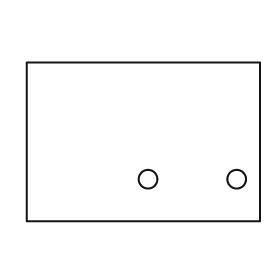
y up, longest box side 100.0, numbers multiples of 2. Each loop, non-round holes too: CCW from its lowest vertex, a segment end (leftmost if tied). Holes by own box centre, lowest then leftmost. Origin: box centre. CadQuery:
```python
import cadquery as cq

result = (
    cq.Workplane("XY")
    .moveTo(-50.0, -34.0)
    .lineTo(50.0, -34.0)
    .lineTo(50.0, 34.0)
    .lineTo(-50.0, 34.0)
    .close()
    .moveTo(2.0, -16.0)
    .circle(4.0)
    .moveTo(40.0, -16.0)
    .circle(4.0)
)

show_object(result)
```